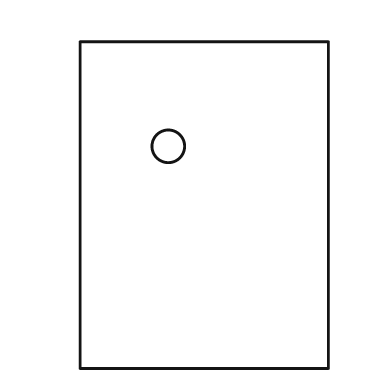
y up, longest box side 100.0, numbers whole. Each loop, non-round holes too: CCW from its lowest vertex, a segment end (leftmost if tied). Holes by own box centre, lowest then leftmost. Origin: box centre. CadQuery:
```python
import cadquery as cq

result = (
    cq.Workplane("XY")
    .moveTo(-38.0, -50.0)
    .lineTo(38.0, -50.0)
    .lineTo(38.0, 50.0)
    .lineTo(-38.0, 50.0)
    .close()
    .moveTo(-11.0, 18.0)
    .circle(5.0)
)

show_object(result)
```